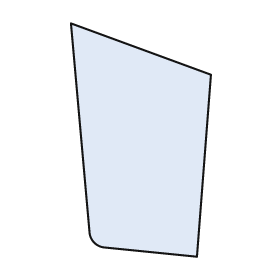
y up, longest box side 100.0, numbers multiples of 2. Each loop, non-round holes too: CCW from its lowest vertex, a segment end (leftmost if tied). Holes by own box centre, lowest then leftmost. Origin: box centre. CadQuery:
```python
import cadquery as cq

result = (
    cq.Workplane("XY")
    .moveTo(24.0, -50.0)
    .lineTo(30.0, 28.0)
    .lineTo(-30.0, 50.0)
    .lineTo(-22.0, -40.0)
    .threePointArc((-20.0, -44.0), (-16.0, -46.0))
    .close()
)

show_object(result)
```